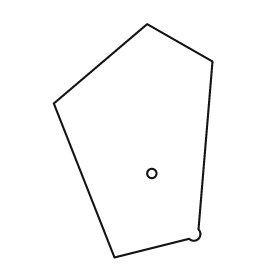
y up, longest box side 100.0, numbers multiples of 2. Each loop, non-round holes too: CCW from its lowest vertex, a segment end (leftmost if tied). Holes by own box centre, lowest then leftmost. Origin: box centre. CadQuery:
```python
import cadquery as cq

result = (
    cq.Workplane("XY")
    .moveTo(-8.0, -50.0)
    .lineTo(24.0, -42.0)
    .threePointArc((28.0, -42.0), (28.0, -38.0))
    .lineTo(34.0, 34.0)
    .lineTo(6.0, 50.0)
    .lineTo(-34.0, 16.0)
    .close()
    .moveTo(8.0, -14.0)
    .circle(2.0)
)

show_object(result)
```